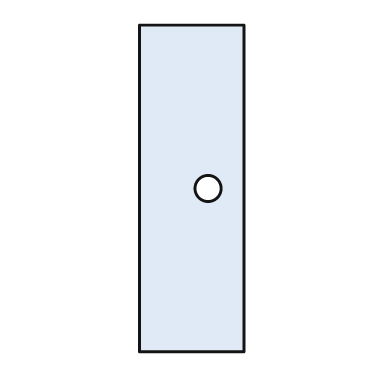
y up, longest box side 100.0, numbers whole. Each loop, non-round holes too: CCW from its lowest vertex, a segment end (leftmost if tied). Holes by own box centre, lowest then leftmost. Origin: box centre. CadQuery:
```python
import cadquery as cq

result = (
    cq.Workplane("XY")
    .moveTo(-16.0, -50.0)
    .lineTo(16.0, -50.0)
    .lineTo(16.0, 50.0)
    .lineTo(-16.0, 50.0)
    .close()
    .moveTo(5.0, 0.0)
    .circle(4.0)
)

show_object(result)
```